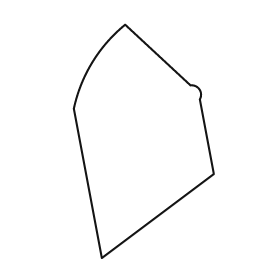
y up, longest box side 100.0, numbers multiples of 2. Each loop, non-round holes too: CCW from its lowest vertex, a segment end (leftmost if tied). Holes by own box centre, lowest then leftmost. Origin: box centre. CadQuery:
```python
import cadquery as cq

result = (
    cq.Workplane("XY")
    .moveTo(-18.0, -50.0)
    .lineTo(30.0, -14.0)
    .lineTo(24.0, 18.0)
    .threePointArc((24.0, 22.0), (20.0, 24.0))
    .lineTo(-8.0, 50.0)
    .threePointArc((-22.0, 34.0), (-30.0, 14.0))
    .close()
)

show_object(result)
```